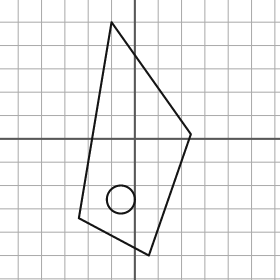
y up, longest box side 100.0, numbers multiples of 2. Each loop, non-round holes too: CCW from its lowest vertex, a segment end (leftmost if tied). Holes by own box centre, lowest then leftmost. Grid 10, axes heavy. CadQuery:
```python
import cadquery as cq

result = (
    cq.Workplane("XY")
    .moveTo(6.0, -50.0)
    .lineTo(24.0, 2.0)
    .lineTo(-10.0, 50.0)
    .lineTo(-24.0, -34.0)
    .close()
    .moveTo(-6.0, -26.0)
    .circle(6.0)
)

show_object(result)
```